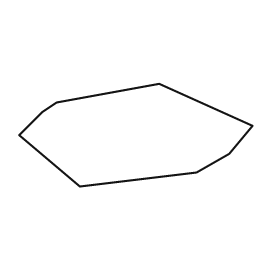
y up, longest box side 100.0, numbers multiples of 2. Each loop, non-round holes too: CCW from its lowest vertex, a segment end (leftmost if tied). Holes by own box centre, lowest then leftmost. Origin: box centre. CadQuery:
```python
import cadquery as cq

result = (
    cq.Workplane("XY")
    .moveTo(-24.0, -22.0)
    .lineTo(26.0, -16.0)
    .lineTo(40.0, -8.0)
    .lineTo(50.0, 4.0)
    .lineTo(10.0, 22.0)
    .lineTo(-34.0, 14.0)
    .lineTo(-40.0, 10.0)
    .lineTo(-50.0, 0.0)
    .close()
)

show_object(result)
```